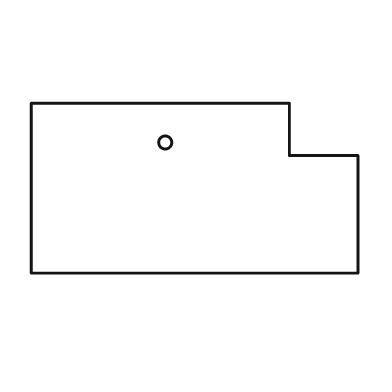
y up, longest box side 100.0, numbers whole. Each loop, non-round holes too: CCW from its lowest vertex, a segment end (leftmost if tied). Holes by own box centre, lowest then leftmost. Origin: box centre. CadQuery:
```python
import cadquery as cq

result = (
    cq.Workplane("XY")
    .moveTo(-50.0, -26.0)
    .lineTo(50.0, -26.0)
    .lineTo(50.0, 10.0)
    .lineTo(29.0, 10.0)
    .lineTo(29.0, 26.0)
    .lineTo(-50.0, 26.0)
    .close()
    .moveTo(-9.0, 14.0)
    .circle(2.0)
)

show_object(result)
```